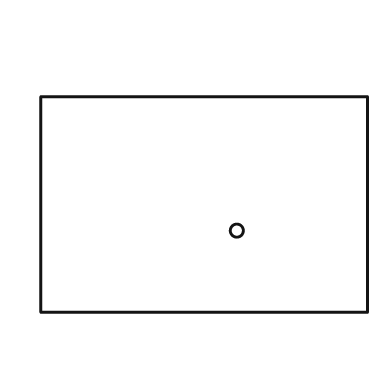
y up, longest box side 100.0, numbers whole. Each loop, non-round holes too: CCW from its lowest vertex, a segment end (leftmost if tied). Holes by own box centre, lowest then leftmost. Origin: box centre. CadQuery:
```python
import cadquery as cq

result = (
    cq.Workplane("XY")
    .moveTo(-50.0, -33.0)
    .lineTo(50.0, -33.0)
    .lineTo(50.0, 33.0)
    .lineTo(-50.0, 33.0)
    .close()
    .moveTo(10.0, -8.0)
    .circle(2.0)
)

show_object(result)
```